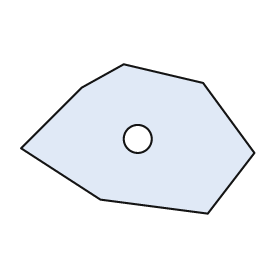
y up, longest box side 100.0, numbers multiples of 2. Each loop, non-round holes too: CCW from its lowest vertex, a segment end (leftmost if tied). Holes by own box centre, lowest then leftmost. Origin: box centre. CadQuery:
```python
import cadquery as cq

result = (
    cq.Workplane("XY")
    .moveTo(30.0, -32.0)
    .lineTo(50.0, -6.0)
    .lineTo(28.0, 24.0)
    .lineTo(-6.0, 32.0)
    .lineTo(-24.0, 22.0)
    .lineTo(-50.0, -4.0)
    .lineTo(-16.0, -26.0)
    .close()
    .moveTo(0.0, 0.0)
    .circle(6.0)
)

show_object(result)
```